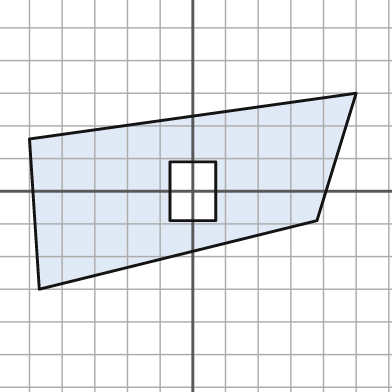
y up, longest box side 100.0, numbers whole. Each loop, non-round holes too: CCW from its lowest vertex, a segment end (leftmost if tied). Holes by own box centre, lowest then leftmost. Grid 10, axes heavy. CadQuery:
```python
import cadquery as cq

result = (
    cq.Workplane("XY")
    .moveTo(-47.0, -30.0)
    .lineTo(38.0, -9.0)
    .lineTo(50.0, 30.0)
    .lineTo(-50.0, 16.0)
    .close()
    .moveTo(-7.0, -9.0)
    .lineTo(7.0, -9.0)
    .lineTo(7.0, 9.0)
    .lineTo(-7.0, 9.0)
    .close()
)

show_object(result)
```